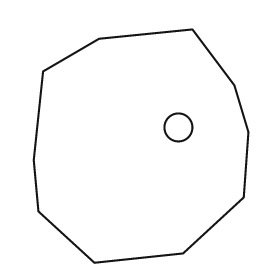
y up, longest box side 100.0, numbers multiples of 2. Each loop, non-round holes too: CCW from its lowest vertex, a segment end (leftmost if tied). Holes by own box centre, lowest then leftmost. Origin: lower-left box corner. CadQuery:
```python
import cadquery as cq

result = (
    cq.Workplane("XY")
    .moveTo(26.0, 0.0)
    .lineTo(64.0, 4.0)
    .lineTo(90.0, 28.0)
    .lineTo(92.0, 56.0)
    .lineTo(86.0, 76.0)
    .lineTo(68.0, 100.0)
    .lineTo(28.0, 96.0)
    .lineTo(4.0, 82.0)
    .lineTo(0.0, 44.0)
    .lineTo(2.0, 22.0)
    .close()
    .moveTo(62.0, 58.0)
    .circle(6.0)
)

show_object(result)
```